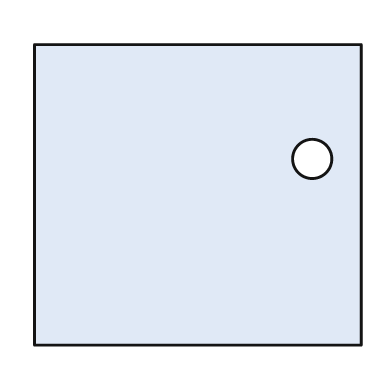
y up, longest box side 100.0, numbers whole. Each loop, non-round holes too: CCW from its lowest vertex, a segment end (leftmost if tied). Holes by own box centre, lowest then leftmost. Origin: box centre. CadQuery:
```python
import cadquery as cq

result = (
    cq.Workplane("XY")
    .moveTo(-50.0, -46.0)
    .lineTo(50.0, -46.0)
    .lineTo(50.0, 46.0)
    .lineTo(-50.0, 46.0)
    .close()
    .moveTo(35.0, 11.0)
    .circle(6.0)
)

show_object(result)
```